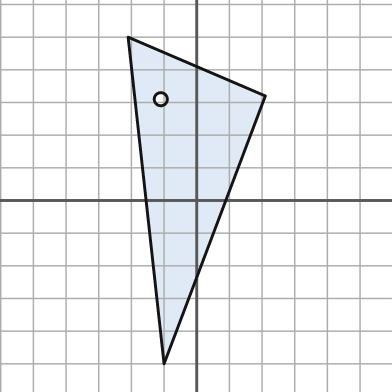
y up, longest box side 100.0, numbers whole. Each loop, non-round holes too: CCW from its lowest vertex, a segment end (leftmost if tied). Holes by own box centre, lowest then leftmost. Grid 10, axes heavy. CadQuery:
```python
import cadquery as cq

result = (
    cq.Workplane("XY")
    .moveTo(-10.0, -50.0)
    .lineTo(21.0, 32.0)
    .lineTo(-21.0, 50.0)
    .close()
    .moveTo(-11.0, 31.0)
    .circle(2.0)
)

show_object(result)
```